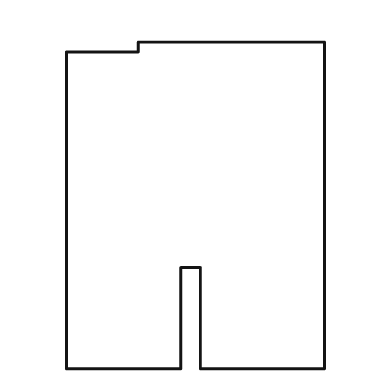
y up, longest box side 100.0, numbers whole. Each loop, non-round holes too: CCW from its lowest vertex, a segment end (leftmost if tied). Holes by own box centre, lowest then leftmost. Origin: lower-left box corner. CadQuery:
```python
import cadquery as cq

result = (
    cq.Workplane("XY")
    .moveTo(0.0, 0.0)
    .lineTo(35.0, 0.0)
    .lineTo(35.0, 31.0)
    .lineTo(41.0, 31.0)
    .lineTo(41.0, 0.0)
    .lineTo(79.0, 0.0)
    .lineTo(79.0, 100.0)
    .lineTo(22.0, 100.0)
    .lineTo(22.0, 97.0)
    .lineTo(0.0, 97.0)
    .close()
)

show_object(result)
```